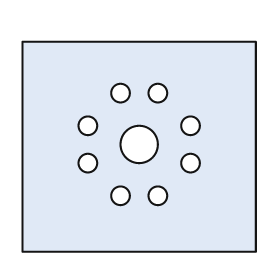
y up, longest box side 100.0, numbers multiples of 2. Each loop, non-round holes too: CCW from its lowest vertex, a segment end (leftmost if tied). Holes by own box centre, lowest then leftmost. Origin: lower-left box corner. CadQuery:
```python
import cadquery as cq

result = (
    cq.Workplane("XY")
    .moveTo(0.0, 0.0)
    .lineTo(100.0, 0.0)
    .lineTo(100.0, 90.0)
    .lineTo(0.0, 90.0)
    .close()
    .moveTo(42.0, 24.0)
    .circle(4.0)
    .moveTo(58.0, 24.0)
    .circle(4.0)
    .moveTo(28.0, 38.0)
    .circle(4.0)
    .moveTo(72.0, 38.0)
    .circle(4.0)
    .moveTo(50.0, 46.0)
    .circle(8.0)
    .moveTo(28.0, 54.0)
    .circle(4.0)
    .moveTo(72.0, 54.0)
    .circle(4.0)
    .moveTo(42.0, 68.0)
    .circle(4.0)
    .moveTo(58.0, 68.0)
    .circle(4.0)
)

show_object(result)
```